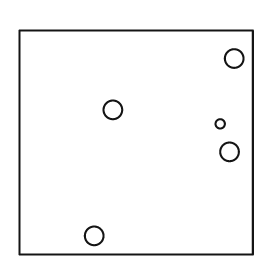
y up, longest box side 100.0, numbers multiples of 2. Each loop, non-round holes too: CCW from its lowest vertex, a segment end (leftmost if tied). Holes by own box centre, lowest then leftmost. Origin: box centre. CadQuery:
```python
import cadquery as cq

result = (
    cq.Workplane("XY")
    .moveTo(-50.0, -48.0)
    .lineTo(50.0, -48.0)
    .lineTo(50.0, 48.0)
    .lineTo(-50.0, 48.0)
    .close()
    .moveTo(-18.0, -40.0)
    .circle(4.0)
    .moveTo(40.0, -4.0)
    .circle(4.0)
    .moveTo(36.0, 8.0)
    .circle(2.0)
    .moveTo(-10.0, 14.0)
    .circle(4.0)
    .moveTo(42.0, 36.0)
    .circle(4.0)
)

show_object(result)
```